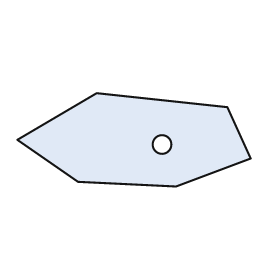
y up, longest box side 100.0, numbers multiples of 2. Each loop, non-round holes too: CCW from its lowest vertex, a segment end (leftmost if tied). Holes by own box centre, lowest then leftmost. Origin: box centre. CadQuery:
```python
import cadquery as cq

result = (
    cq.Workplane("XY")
    .moveTo(18.0, -20.0)
    .lineTo(50.0, -8.0)
    .lineTo(40.0, 14.0)
    .lineTo(-16.0, 20.0)
    .lineTo(-50.0, 0.0)
    .lineTo(-24.0, -18.0)
    .close()
    .moveTo(12.0, -2.0)
    .circle(4.0)
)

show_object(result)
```